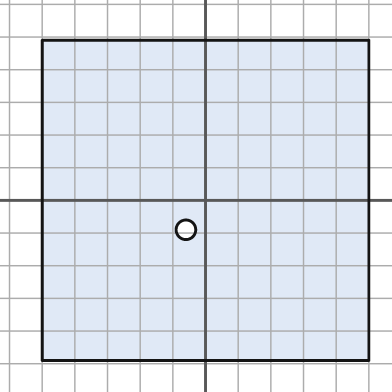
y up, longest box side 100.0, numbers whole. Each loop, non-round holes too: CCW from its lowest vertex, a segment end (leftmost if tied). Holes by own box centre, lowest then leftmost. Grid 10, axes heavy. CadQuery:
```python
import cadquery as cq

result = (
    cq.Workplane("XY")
    .moveTo(-50.0, -49.0)
    .lineTo(50.0, -49.0)
    .lineTo(50.0, 49.0)
    .lineTo(-50.0, 49.0)
    .close()
    .moveTo(-6.0, -9.0)
    .circle(3.0)
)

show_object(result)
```